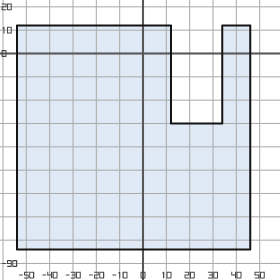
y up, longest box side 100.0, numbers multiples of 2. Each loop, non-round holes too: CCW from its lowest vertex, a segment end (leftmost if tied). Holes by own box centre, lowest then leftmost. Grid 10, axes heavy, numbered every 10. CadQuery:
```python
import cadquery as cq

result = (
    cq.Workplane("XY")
    .moveTo(-54.0, -84.0)
    .lineTo(46.0, -84.0)
    .lineTo(46.0, 12.0)
    .lineTo(34.0, 12.0)
    .lineTo(34.0, -30.0)
    .lineTo(12.0, -30.0)
    .lineTo(12.0, 12.0)
    .lineTo(-54.0, 12.0)
    .close()
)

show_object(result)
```